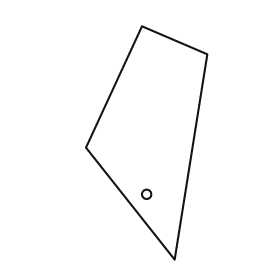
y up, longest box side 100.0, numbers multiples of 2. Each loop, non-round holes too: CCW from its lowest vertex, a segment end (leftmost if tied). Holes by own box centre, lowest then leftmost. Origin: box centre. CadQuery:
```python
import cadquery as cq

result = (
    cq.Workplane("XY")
    .moveTo(12.0, -50.0)
    .lineTo(26.0, 38.0)
    .lineTo(-2.0, 50.0)
    .lineTo(-26.0, -2.0)
    .close()
    .moveTo(0.0, -22.0)
    .circle(2.0)
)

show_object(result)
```